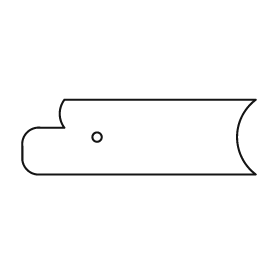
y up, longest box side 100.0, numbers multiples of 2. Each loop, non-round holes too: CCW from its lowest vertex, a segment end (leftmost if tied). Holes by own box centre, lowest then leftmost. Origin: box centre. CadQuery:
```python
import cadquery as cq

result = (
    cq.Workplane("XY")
    .moveTo(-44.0, -16.0)
    .lineTo(50.0, -16.0)
    .threePointArc((42.0, 0.0), (50.0, 16.0))
    .lineTo(-32.0, 16.0)
    .threePointArc((-34.0, 10.0), (-32.0, 4.0))
    .lineTo(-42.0, 4.0)
    .threePointArc((-48.0, 2.0), (-50.0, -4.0))
    .lineTo(-50.0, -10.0)
    .threePointArc((-48.0, -14.0), (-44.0, -16.0))
    .close()
    .moveTo(-18.0, 0.0)
    .circle(2.0)
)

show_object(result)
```